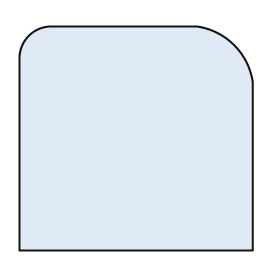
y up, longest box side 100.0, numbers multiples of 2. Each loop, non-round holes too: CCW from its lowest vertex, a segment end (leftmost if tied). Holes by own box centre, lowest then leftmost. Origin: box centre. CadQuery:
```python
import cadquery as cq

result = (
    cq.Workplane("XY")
    .moveTo(-50.0, -48.0)
    .lineTo(50.0, -48.0)
    .lineTo(50.0, 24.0)
    .threePointArc((42.0, 40.0), (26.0, 48.0))
    .lineTo(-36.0, 48.0)
    .threePointArc((-46.0, 44.0), (-50.0, 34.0))
    .close()
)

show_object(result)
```